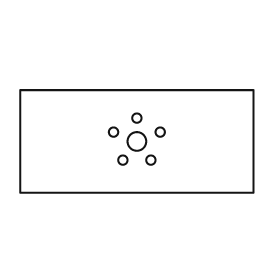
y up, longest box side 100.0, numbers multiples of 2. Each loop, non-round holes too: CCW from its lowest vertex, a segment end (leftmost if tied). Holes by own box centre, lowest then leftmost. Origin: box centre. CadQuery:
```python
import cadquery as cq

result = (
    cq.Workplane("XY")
    .moveTo(-50.0, -22.0)
    .lineTo(50.0, -22.0)
    .lineTo(50.0, 22.0)
    .lineTo(-50.0, 22.0)
    .close()
    .moveTo(-6.0, -8.0)
    .circle(2.0)
    .moveTo(6.0, -8.0)
    .circle(2.0)
    .moveTo(0.0, 0.0)
    .circle(4.0)
    .moveTo(-10.0, 4.0)
    .circle(2.0)
    .moveTo(10.0, 4.0)
    .circle(2.0)
    .moveTo(0.0, 10.0)
    .circle(2.0)
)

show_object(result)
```